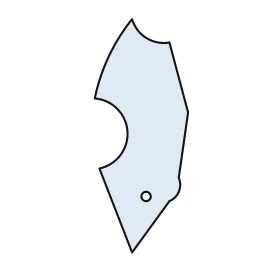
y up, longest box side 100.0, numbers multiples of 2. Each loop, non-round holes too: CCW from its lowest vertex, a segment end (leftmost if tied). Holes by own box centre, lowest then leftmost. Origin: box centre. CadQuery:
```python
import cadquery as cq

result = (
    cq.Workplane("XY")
    .moveTo(-4.0, -50.0)
    .lineTo(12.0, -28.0)
    .threePointArc((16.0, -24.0), (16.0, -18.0))
    .lineTo(20.0, 10.0)
    .lineTo(12.0, 40.0)
    .threePointArc((2.0, 42.0), (-4.0, 50.0))
    .threePointArc((-14.0, 34.0), (-20.0, 16.0))
    .threePointArc((-6.0, 2.0), (-18.0, -14.0))
    .close()
    .moveTo(2.0, -26.0)
    .circle(2.0)
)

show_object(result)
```